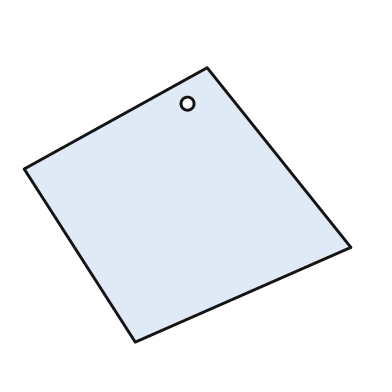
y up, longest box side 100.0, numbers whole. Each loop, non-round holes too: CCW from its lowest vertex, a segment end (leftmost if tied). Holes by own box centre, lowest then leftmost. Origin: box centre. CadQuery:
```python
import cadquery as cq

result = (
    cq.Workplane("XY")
    .moveTo(-16.0, -42.0)
    .lineTo(50.0, -13.0)
    .lineTo(6.0, 42.0)
    .lineTo(-50.0, 11.0)
    .close()
    .moveTo(0.0, 31.0)
    .circle(2.0)
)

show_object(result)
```